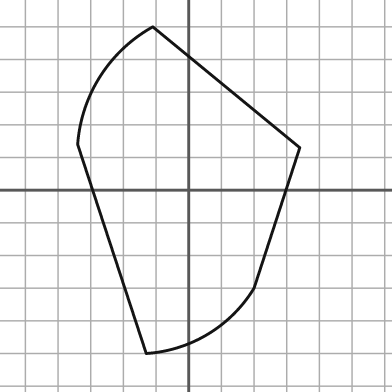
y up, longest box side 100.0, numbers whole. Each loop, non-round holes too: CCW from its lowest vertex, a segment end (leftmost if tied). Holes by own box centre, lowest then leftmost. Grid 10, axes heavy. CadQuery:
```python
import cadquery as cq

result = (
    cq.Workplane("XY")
    .moveTo(-13.0, -50.0)
    .threePointArc((6.0, -44.0), (20.0, -30.0))
    .lineTo(34.0, 13.0)
    .lineTo(-11.0, 50.0)
    .threePointArc((-27.0, 35.0), (-34.0, 14.0))
    .close()
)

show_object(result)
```